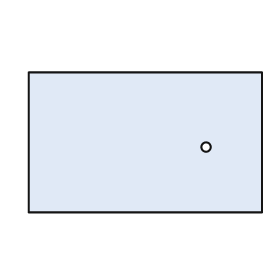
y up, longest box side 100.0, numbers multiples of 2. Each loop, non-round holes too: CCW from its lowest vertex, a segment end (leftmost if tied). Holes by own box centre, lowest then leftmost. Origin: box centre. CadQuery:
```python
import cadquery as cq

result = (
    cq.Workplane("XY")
    .moveTo(-50.0, -30.0)
    .lineTo(50.0, -30.0)
    .lineTo(50.0, 30.0)
    .lineTo(-50.0, 30.0)
    .close()
    .moveTo(26.0, -2.0)
    .circle(2.0)
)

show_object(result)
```